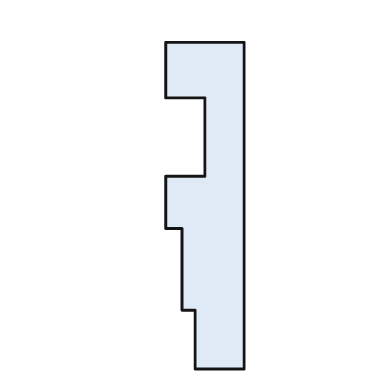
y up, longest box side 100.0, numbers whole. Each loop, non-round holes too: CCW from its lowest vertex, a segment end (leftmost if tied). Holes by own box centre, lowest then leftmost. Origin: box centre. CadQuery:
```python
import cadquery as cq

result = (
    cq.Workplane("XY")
    .moveTo(-3.0, -50.0)
    .lineTo(12.0, -50.0)
    .lineTo(12.0, 50.0)
    .lineTo(-12.0, 50.0)
    .lineTo(-12.0, 33.0)
    .lineTo(0.0, 33.0)
    .lineTo(0.0, 9.0)
    .lineTo(-12.0, 9.0)
    .lineTo(-12.0, -7.0)
    .lineTo(-7.0, -7.0)
    .lineTo(-7.0, -32.0)
    .lineTo(-3.0, -32.0)
    .close()
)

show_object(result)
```